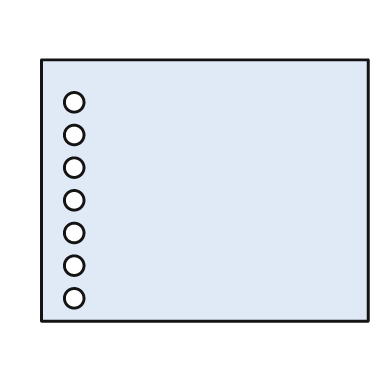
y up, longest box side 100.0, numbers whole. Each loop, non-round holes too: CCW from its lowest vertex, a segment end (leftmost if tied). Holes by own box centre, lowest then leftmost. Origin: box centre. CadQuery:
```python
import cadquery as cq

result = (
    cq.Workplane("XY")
    .moveTo(-50.0, -40.0)
    .lineTo(50.0, -40.0)
    .lineTo(50.0, 40.0)
    .lineTo(-50.0, 40.0)
    .close()
    .moveTo(-40.0, -33.0)
    .circle(3.0)
    .moveTo(-40.0, -23.0)
    .circle(3.0)
    .moveTo(-40.0, -13.0)
    .circle(3.0)
    .moveTo(-40.0, -3.0)
    .circle(3.0)
    .moveTo(-40.0, 7.0)
    .circle(3.0)
    .moveTo(-40.0, 17.0)
    .circle(3.0)
    .moveTo(-40.0, 27.0)
    .circle(3.0)
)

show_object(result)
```